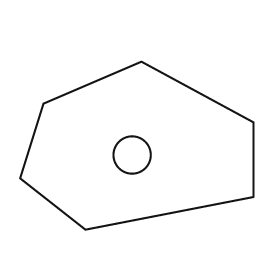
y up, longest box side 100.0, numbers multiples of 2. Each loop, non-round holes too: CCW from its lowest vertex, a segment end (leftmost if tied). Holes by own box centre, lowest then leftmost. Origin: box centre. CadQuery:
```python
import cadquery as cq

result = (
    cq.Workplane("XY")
    .moveTo(-22.0, -36.0)
    .lineTo(50.0, -22.0)
    .lineTo(50.0, 10.0)
    .lineTo(2.0, 36.0)
    .lineTo(-40.0, 18.0)
    .lineTo(-50.0, -14.0)
    .close()
    .moveTo(-2.0, -4.0)
    .circle(8.0)
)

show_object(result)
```